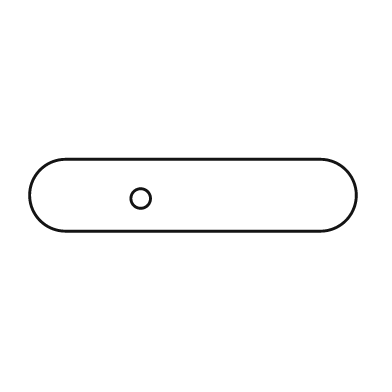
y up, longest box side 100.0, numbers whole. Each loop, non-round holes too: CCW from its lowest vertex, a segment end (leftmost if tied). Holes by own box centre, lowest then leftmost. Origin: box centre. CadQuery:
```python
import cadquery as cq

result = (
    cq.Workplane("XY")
    .moveTo(-39.0, -11.0)
    .lineTo(39.0, -11.0)
    .threePointArc((50.0, 0.0), (39.0, 11.0))
    .lineTo(-39.0, 11.0)
    .threePointArc((-50.0, 0.0), (-39.0, -11.0))
    .close()
    .moveTo(-16.0, -1.0)
    .circle(3.0)
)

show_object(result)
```